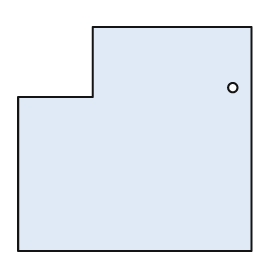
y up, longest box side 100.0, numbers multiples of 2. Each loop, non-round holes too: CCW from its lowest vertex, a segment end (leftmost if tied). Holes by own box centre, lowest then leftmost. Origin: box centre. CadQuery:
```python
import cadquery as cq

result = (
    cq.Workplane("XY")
    .moveTo(-50.0, -48.0)
    .lineTo(50.0, -48.0)
    .lineTo(50.0, 48.0)
    .lineTo(-18.0, 48.0)
    .lineTo(-18.0, 18.0)
    .lineTo(-50.0, 18.0)
    .close()
    .moveTo(42.0, 22.0)
    .circle(2.0)
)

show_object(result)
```